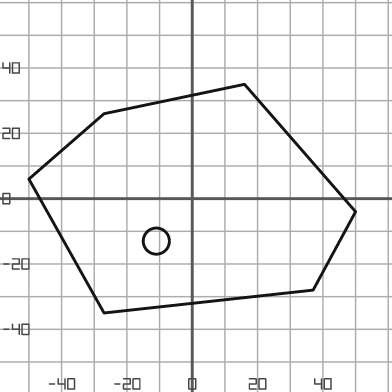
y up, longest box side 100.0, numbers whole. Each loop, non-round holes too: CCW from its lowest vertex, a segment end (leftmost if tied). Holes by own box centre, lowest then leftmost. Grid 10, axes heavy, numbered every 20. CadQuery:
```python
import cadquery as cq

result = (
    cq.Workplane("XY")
    .moveTo(-27.0, -35.0)
    .lineTo(37.0, -28.0)
    .lineTo(50.0, -4.0)
    .lineTo(16.0, 35.0)
    .lineTo(-27.0, 26.0)
    .lineTo(-50.0, 6.0)
    .close()
    .moveTo(-11.0, -13.0)
    .circle(4.0)
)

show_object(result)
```